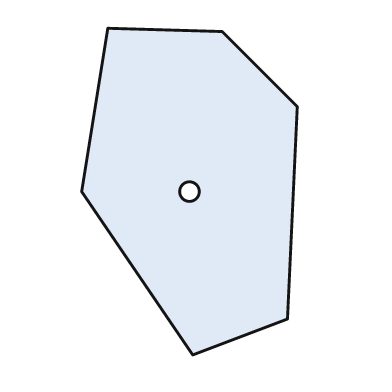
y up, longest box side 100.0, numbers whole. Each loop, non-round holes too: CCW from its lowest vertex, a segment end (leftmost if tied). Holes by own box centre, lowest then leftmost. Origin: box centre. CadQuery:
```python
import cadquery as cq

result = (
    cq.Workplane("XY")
    .moveTo(1.0, -50.0)
    .lineTo(30.0, -39.0)
    .lineTo(33.0, 26.0)
    .lineTo(10.0, 49.0)
    .lineTo(-25.0, 50.0)
    .lineTo(-33.0, 0.0)
    .close()
    .moveTo(0.0, 0.0)
    .circle(3.0)
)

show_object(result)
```